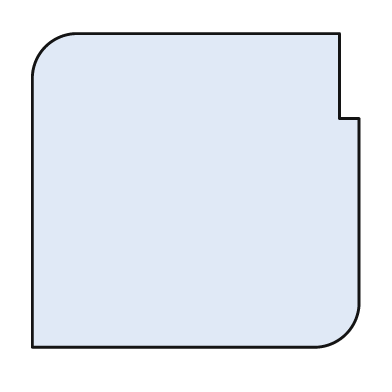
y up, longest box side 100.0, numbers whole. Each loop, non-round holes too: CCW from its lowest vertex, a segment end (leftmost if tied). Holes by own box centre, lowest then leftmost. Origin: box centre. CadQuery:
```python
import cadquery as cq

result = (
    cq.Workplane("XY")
    .moveTo(-50.0, -48.0)
    .lineTo(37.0, -48.0)
    .threePointArc((46.0, -44.0), (50.0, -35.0))
    .lineTo(50.0, 22.0)
    .lineTo(44.0, 22.0)
    .lineTo(44.0, 48.0)
    .lineTo(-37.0, 48.0)
    .threePointArc((-46.0, 44.0), (-50.0, 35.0))
    .close()
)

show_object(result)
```